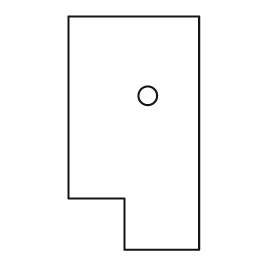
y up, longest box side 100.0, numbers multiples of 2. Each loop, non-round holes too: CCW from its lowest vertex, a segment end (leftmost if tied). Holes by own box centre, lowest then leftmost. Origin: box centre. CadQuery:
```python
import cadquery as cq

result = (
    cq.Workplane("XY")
    .moveTo(-4.0, -50.0)
    .lineTo(28.0, -50.0)
    .lineTo(28.0, 50.0)
    .lineTo(-28.0, 50.0)
    .lineTo(-28.0, -28.0)
    .lineTo(-4.0, -28.0)
    .close()
    .moveTo(6.0, 16.0)
    .circle(4.0)
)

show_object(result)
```